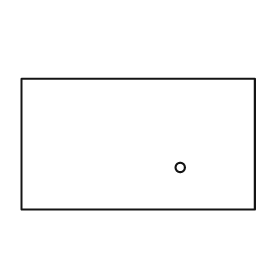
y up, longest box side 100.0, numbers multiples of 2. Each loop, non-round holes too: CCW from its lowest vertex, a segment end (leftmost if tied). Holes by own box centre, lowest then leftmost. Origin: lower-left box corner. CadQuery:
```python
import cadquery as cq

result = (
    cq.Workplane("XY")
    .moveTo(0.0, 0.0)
    .lineTo(100.0, 0.0)
    .lineTo(100.0, 56.0)
    .lineTo(0.0, 56.0)
    .close()
    .moveTo(68.0, 18.0)
    .circle(2.0)
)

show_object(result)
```